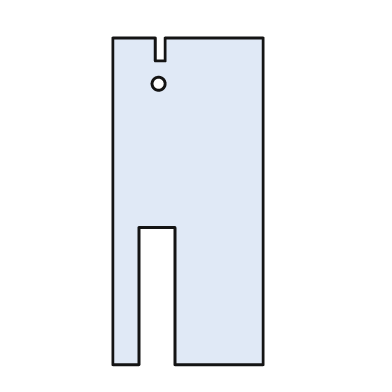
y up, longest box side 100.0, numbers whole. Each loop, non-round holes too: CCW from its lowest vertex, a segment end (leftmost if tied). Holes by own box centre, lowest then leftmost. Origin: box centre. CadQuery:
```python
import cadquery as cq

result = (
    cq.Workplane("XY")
    .moveTo(-23.0, -50.0)
    .lineTo(-15.0, -50.0)
    .lineTo(-15.0, -8.0)
    .lineTo(-4.0, -8.0)
    .lineTo(-4.0, -50.0)
    .lineTo(23.0, -50.0)
    .lineTo(23.0, 50.0)
    .lineTo(-7.0, 50.0)
    .lineTo(-7.0, 43.0)
    .lineTo(-10.0, 43.0)
    .lineTo(-10.0, 50.0)
    .lineTo(-23.0, 50.0)
    .close()
    .moveTo(-9.0, 36.0)
    .circle(2.0)
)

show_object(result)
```